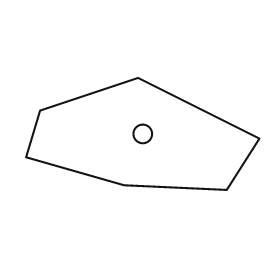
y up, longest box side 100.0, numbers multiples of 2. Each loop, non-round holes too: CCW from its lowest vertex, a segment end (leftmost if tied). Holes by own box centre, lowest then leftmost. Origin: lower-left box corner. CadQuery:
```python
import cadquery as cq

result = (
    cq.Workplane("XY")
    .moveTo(86.0, 0.0)
    .lineTo(100.0, 22.0)
    .lineTo(48.0, 48.0)
    .lineTo(6.0, 34.0)
    .lineTo(0.0, 14.0)
    .lineTo(42.0, 2.0)
    .close()
    .moveTo(50.0, 24.0)
    .circle(4.0)
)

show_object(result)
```